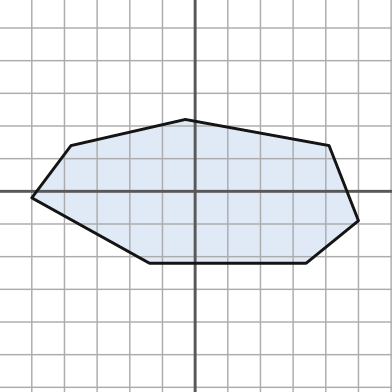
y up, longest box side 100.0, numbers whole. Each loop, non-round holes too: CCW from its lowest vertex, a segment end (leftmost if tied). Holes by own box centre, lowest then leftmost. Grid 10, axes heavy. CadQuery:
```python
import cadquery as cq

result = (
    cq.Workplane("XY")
    .moveTo(-14.0, -22.0)
    .lineTo(34.0, -22.0)
    .lineTo(50.0, -9.0)
    .lineTo(41.0, 14.0)
    .lineTo(-3.0, 22.0)
    .lineTo(-38.0, 14.0)
    .lineTo(-50.0, -2.0)
    .close()
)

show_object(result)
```